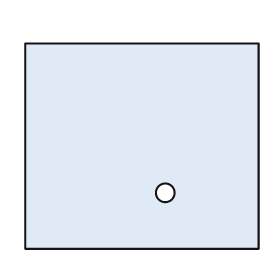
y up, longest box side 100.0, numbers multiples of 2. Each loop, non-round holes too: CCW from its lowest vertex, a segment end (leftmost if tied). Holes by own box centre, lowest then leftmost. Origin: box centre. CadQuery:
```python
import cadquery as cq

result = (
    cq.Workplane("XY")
    .moveTo(-50.0, -44.0)
    .lineTo(50.0, -44.0)
    .lineTo(50.0, 44.0)
    .lineTo(-50.0, 44.0)
    .close()
    .moveTo(10.0, -20.0)
    .circle(4.0)
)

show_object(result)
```